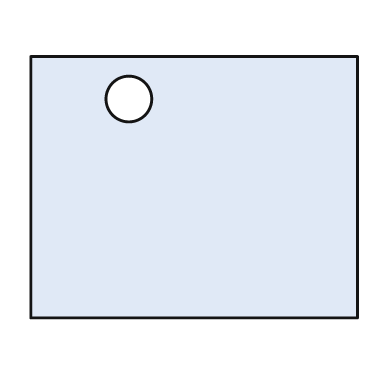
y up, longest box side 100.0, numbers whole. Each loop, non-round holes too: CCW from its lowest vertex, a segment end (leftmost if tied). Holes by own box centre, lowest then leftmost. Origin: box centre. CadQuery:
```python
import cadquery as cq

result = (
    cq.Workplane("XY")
    .moveTo(-50.0, -40.0)
    .lineTo(50.0, -40.0)
    .lineTo(50.0, 40.0)
    .lineTo(-50.0, 40.0)
    .close()
    .moveTo(-20.0, 27.0)
    .circle(7.0)
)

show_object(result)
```